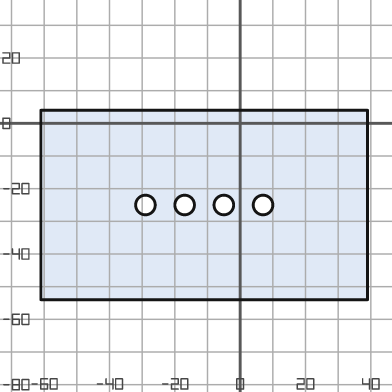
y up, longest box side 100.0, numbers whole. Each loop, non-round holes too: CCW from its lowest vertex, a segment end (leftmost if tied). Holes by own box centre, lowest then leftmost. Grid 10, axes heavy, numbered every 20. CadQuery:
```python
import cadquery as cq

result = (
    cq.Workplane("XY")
    .moveTo(-61.0, -54.0)
    .lineTo(39.0, -54.0)
    .lineTo(39.0, 4.0)
    .lineTo(-61.0, 4.0)
    .close()
    .moveTo(-29.0, -25.0)
    .circle(3.0)
    .moveTo(-17.0, -25.0)
    .circle(3.0)
    .moveTo(-5.0, -25.0)
    .circle(3.0)
    .moveTo(7.0, -25.0)
    .circle(3.0)
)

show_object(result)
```